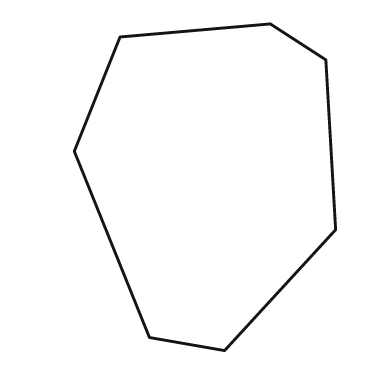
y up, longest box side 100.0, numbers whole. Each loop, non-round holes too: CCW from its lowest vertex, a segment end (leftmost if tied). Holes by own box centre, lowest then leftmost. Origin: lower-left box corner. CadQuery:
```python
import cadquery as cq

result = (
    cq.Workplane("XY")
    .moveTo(46.0, 0.0)
    .lineTo(80.0, 37.0)
    .lineTo(77.0, 89.0)
    .lineTo(60.0, 100.0)
    .lineTo(14.0, 96.0)
    .lineTo(0.0, 61.0)
    .lineTo(23.0, 4.0)
    .close()
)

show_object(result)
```